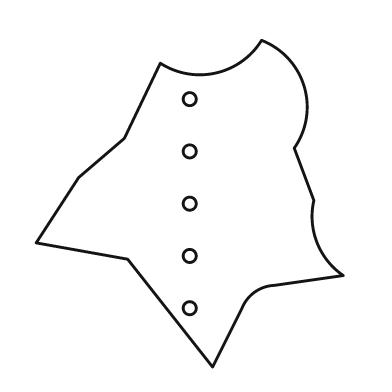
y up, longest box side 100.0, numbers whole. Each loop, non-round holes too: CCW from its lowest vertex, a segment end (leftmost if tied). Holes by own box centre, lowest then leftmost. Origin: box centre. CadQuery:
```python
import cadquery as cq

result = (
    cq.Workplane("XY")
    .moveTo(7.0, -50.0)
    .lineTo(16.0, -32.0)
    .threePointArc((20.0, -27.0), (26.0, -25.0))
    .lineTo(47.0, -22.0)
    .threePointArc((39.0, -12.0), (38.0, 1.0))
    .lineTo(32.0, 17.0)
    .threePointArc((35.0, 36.0), (22.0, 50.0))
    .threePointArc((8.0, 40.0), (-9.0, 43.0))
    .lineTo(-20.0, 20.0)
    .lineTo(-34.0, 8.0)
    .lineTo(-47.0, -12.0)
    .lineTo(-19.0, -17.0)
    .close()
    .moveTo(0.0, -32.0)
    .circle(2.0)
    .moveTo(0.0, -16.0)
    .circle(2.0)
    .moveTo(0.0, 0.0)
    .circle(2.0)
    .moveTo(0.0, 16.0)
    .circle(2.0)
    .moveTo(0.0, 32.0)
    .circle(2.0)
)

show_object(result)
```